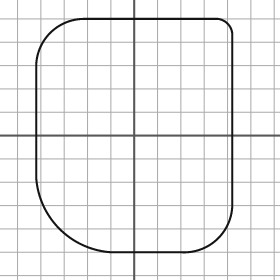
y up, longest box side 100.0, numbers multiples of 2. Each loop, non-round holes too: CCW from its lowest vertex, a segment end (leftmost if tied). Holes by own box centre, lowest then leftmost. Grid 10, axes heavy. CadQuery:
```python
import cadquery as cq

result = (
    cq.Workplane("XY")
    .moveTo(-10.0, -50.0)
    .lineTo(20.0, -50.0)
    .threePointArc((36.0, -44.0), (42.0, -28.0))
    .lineTo(42.0, 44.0)
    .threePointArc((40.0, 48.0), (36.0, 50.0))
    .lineTo(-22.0, 50.0)
    .threePointArc((-36.0, 44.0), (-42.0, 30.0))
    .lineTo(-42.0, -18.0)
    .threePointArc((-32.0, -40.0), (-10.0, -50.0))
    .close()
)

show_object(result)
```